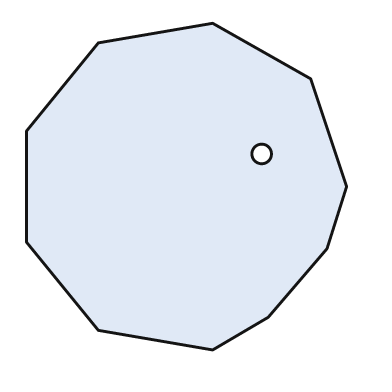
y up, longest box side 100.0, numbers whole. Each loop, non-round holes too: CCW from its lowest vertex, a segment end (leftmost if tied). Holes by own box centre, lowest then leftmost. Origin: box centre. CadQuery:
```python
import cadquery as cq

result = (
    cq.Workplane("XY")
    .moveTo(8.0, -50.0)
    .lineTo(25.0, -40.0)
    .lineTo(43.0, -19.0)
    .lineTo(49.0, 0.0)
    .lineTo(38.0, 33.0)
    .lineTo(8.0, 50.0)
    .lineTo(-27.0, 44.0)
    .lineTo(-49.0, 17.0)
    .lineTo(-49.0, -17.0)
    .lineTo(-27.0, -44.0)
    .close()
    .moveTo(23.0, 10.0)
    .circle(3.0)
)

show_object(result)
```